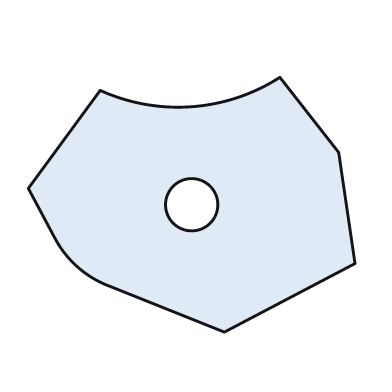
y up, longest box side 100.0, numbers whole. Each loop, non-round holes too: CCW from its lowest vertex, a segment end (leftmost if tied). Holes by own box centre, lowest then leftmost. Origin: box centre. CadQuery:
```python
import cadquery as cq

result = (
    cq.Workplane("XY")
    .moveTo(10.0, -39.0)
    .lineTo(50.0, -18.0)
    .lineTo(45.0, 16.0)
    .lineTo(27.0, 39.0)
    .threePointArc((0.0, 30.0), (-28.0, 35.0))
    .lineTo(-50.0, 5.0)
    .lineTo(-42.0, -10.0)
    .threePointArc((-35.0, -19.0), (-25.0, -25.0))
    .close()
    .moveTo(0.0, 0.0)
    .circle(8.0)
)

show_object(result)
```